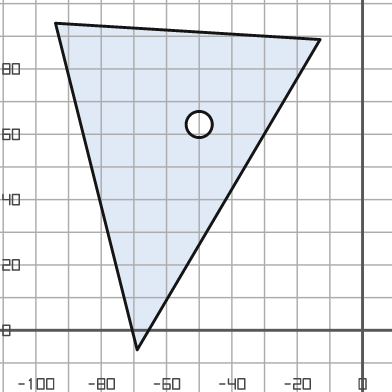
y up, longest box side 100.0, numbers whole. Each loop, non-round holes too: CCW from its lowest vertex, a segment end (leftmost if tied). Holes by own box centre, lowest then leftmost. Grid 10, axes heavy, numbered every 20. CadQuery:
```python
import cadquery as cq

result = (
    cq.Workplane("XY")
    .moveTo(-69.0, -6.0)
    .lineTo(-13.0, 89.0)
    .lineTo(-94.0, 94.0)
    .close()
    .moveTo(-50.0, 63.0)
    .circle(4.0)
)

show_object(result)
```